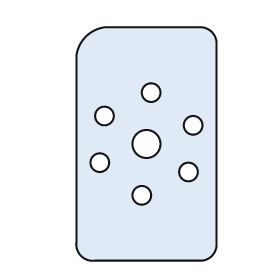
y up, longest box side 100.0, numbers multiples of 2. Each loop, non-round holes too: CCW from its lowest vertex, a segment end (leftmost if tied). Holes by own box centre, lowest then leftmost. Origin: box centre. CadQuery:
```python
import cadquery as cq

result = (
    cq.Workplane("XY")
    .moveTo(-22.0, -50.0)
    .lineTo(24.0, -50.0)
    .threePointArc((28.0, -48.0), (30.0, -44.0))
    .lineTo(30.0, 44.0)
    .threePointArc((28.0, 48.0), (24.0, 50.0))
    .lineTo(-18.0, 50.0)
    .threePointArc((-26.0, 46.0), (-30.0, 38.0))
    .lineTo(-30.0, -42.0)
    .threePointArc((-28.0, -48.0), (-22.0, -50.0))
    .close()
    .moveTo(-2.0, -22.0)
    .circle(4.0)
    .moveTo(18.0, -12.0)
    .circle(4.0)
    .moveTo(-20.0, -8.0)
    .circle(4.0)
    .moveTo(0.0, 0.0)
    .circle(6.0)
    .moveTo(20.0, 8.0)
    .circle(4.0)
    .moveTo(-18.0, 12.0)
    .circle(4.0)
    .moveTo(2.0, 22.0)
    .circle(4.0)
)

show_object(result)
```